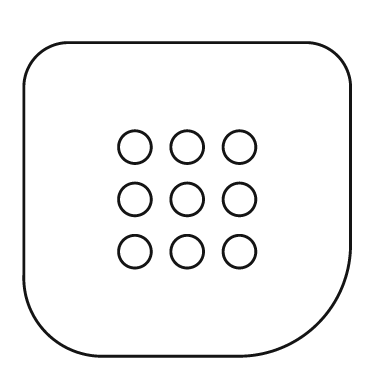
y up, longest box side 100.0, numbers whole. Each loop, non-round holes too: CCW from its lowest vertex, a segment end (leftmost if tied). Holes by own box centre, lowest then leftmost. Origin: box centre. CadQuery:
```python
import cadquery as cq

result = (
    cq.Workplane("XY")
    .moveTo(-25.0, -48.0)
    .lineTo(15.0, -48.0)
    .threePointArc((40.0, -38.0), (50.0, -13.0))
    .lineTo(50.0, 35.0)
    .threePointArc((46.0, 44.0), (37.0, 48.0))
    .lineTo(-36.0, 48.0)
    .threePointArc((-46.0, 44.0), (-50.0, 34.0))
    .lineTo(-50.0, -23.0)
    .threePointArc((-43.0, -41.0), (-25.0, -48.0))
    .close()
    .moveTo(-16.0, -16.0)
    .circle(5.0)
    .moveTo(0.0, -16.0)
    .circle(5.0)
    .moveTo(16.0, -16.0)
    .circle(5.0)
    .moveTo(-16.0, 0.0)
    .circle(5.0)
    .moveTo(0.0, 0.0)
    .circle(5.0)
    .moveTo(16.0, 0.0)
    .circle(5.0)
    .moveTo(-16.0, 16.0)
    .circle(5.0)
    .moveTo(0.0, 16.0)
    .circle(5.0)
    .moveTo(16.0, 16.0)
    .circle(5.0)
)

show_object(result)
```